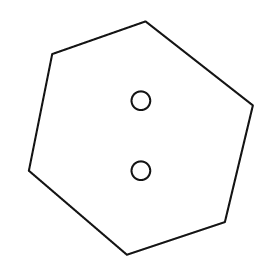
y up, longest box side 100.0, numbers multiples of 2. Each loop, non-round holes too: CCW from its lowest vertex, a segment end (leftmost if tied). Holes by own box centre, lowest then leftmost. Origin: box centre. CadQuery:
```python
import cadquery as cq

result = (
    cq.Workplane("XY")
    .moveTo(-6.0, -50.0)
    .lineTo(36.0, -36.0)
    .lineTo(48.0, 14.0)
    .lineTo(2.0, 50.0)
    .lineTo(-38.0, 36.0)
    .lineTo(-48.0, -14.0)
    .close()
    .moveTo(0.0, -14.0)
    .circle(4.0)
    .moveTo(0.0, 16.0)
    .circle(4.0)
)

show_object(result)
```